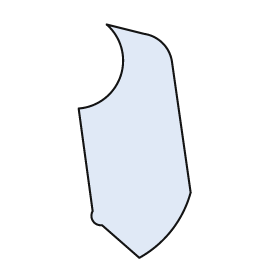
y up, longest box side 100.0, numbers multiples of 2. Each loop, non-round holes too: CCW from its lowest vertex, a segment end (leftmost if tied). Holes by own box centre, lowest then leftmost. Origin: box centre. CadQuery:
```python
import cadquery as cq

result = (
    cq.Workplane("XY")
    .moveTo(2.0, -50.0)
    .threePointArc((16.0, -38.0), (24.0, -22.0))
    .lineTo(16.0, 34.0)
    .threePointArc((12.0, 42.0), (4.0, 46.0))
    .lineTo(-12.0, 50.0)
    .threePointArc((-6.0, 28.0), (-24.0, 14.0))
    .lineTo(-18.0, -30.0)
    .threePointArc((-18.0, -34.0), (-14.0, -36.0))
    .close()
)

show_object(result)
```